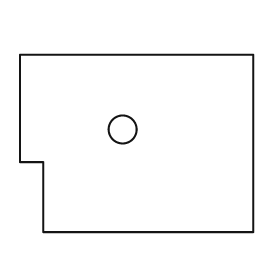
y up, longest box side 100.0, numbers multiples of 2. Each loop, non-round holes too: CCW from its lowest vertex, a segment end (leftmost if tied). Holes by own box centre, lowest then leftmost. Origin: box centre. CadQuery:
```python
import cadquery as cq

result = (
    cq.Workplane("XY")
    .moveTo(-40.0, -38.0)
    .lineTo(50.0, -38.0)
    .lineTo(50.0, 38.0)
    .lineTo(-50.0, 38.0)
    .lineTo(-50.0, -8.0)
    .lineTo(-40.0, -8.0)
    .close()
    .moveTo(-6.0, 6.0)
    .circle(6.0)
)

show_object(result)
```